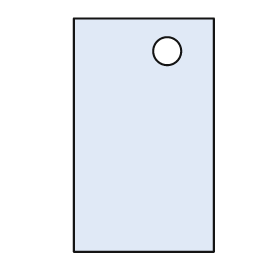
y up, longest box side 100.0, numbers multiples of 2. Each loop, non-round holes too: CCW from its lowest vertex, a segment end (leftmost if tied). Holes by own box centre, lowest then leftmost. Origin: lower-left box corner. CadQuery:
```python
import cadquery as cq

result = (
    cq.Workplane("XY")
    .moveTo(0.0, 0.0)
    .lineTo(60.0, 0.0)
    .lineTo(60.0, 100.0)
    .lineTo(0.0, 100.0)
    .close()
    .moveTo(40.0, 86.0)
    .circle(6.0)
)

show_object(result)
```